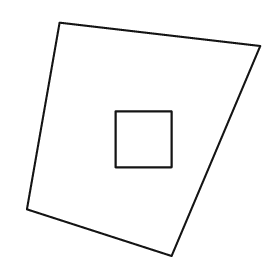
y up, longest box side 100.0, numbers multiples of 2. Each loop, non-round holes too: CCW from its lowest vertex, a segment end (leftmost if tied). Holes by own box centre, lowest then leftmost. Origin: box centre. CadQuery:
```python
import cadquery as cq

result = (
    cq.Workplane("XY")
    .moveTo(12.0, -50.0)
    .lineTo(50.0, 40.0)
    .lineTo(-36.0, 50.0)
    .lineTo(-50.0, -30.0)
    .close()
    .moveTo(-12.0, -12.0)
    .lineTo(12.0, -12.0)
    .lineTo(12.0, 12.0)
    .lineTo(-12.0, 12.0)
    .close()
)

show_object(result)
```